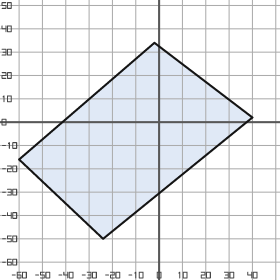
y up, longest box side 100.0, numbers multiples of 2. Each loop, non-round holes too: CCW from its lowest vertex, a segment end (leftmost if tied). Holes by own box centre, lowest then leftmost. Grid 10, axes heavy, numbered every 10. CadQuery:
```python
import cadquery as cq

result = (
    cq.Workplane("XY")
    .moveTo(-24.0, -50.0)
    .lineTo(40.0, 2.0)
    .lineTo(-2.0, 34.0)
    .lineTo(-60.0, -16.0)
    .close()
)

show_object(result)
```